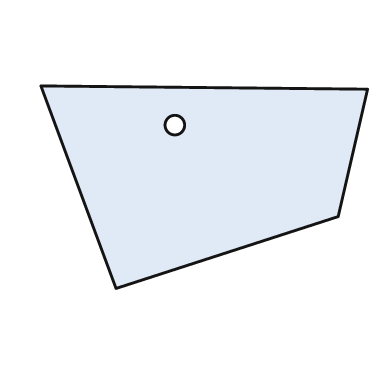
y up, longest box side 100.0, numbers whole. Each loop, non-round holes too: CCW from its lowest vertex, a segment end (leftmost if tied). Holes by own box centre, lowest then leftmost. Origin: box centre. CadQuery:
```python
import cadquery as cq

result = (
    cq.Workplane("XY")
    .moveTo(-27.0, -31.0)
    .lineTo(41.0, -9.0)
    .lineTo(50.0, 30.0)
    .lineTo(-50.0, 31.0)
    .close()
    .moveTo(-9.0, 19.0)
    .circle(3.0)
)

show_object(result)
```